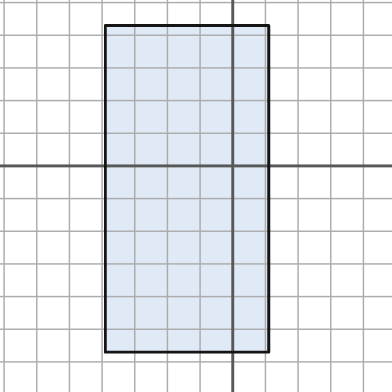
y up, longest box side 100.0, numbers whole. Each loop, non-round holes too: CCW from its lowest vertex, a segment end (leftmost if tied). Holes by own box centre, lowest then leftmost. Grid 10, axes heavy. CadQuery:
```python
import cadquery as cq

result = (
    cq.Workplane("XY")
    .moveTo(-39.0, -57.0)
    .lineTo(11.0, -57.0)
    .lineTo(11.0, 43.0)
    .lineTo(-39.0, 43.0)
    .close()
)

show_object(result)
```